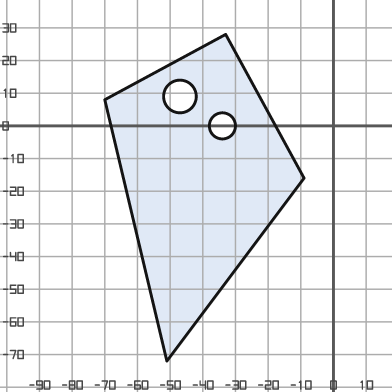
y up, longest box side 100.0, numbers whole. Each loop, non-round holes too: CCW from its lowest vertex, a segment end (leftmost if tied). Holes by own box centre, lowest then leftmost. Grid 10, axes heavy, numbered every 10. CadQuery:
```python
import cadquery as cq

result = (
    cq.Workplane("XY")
    .moveTo(-51.0, -72.0)
    .lineTo(-9.0, -16.0)
    .lineTo(-33.0, 28.0)
    .lineTo(-70.0, 8.0)
    .close()
    .moveTo(-34.0, 0.0)
    .circle(4.0)
    .moveTo(-47.0, 9.0)
    .circle(5.0)
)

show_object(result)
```